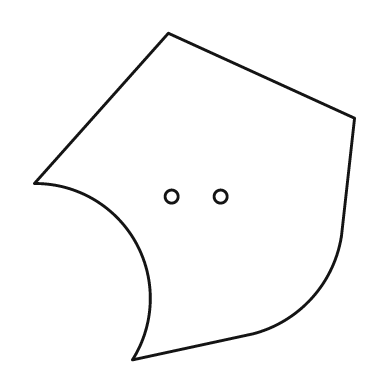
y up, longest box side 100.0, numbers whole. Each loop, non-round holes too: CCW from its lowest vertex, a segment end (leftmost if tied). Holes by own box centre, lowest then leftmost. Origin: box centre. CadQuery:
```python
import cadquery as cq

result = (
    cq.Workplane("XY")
    .moveTo(-19.0, -50.0)
    .lineTo(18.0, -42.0)
    .threePointArc((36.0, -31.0), (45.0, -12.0))
    .lineTo(49.0, 24.0)
    .lineTo(-8.0, 50.0)
    .lineTo(-49.0, 4.0)
    .threePointArc((-18.0, -14.0), (-19.0, -50.0))
    .close()
    .moveTo(-7.0, 0.0)
    .circle(2.0)
    .moveTo(8.0, 0.0)
    .circle(2.0)
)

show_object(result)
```